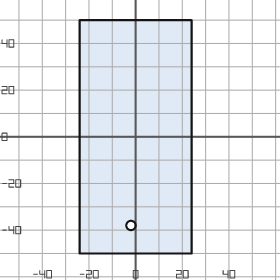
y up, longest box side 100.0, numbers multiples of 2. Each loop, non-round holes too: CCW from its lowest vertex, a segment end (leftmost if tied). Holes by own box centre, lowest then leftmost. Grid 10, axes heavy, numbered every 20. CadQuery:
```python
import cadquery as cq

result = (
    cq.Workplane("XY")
    .moveTo(-24.0, -50.0)
    .lineTo(24.0, -50.0)
    .lineTo(24.0, 50.0)
    .lineTo(-24.0, 50.0)
    .close()
    .moveTo(-2.0, -38.0)
    .circle(2.0)
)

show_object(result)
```